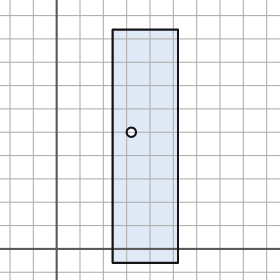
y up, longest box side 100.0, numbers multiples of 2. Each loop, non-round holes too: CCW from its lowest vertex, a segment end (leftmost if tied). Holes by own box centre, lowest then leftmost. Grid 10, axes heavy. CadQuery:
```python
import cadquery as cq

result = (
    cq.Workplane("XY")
    .moveTo(24.0, -6.0)
    .lineTo(52.0, -6.0)
    .lineTo(52.0, 94.0)
    .lineTo(24.0, 94.0)
    .close()
    .moveTo(32.0, 50.0)
    .circle(2.0)
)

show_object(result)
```